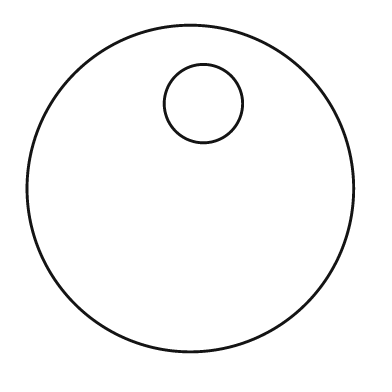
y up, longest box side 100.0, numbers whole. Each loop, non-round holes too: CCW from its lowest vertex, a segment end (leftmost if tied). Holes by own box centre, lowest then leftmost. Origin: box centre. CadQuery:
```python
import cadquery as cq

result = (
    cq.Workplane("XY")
    .moveTo(0.0, 0.0)
    .circle(50.0)
    .moveTo(4.0, 26.0)
    .circle(12.0)
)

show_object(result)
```